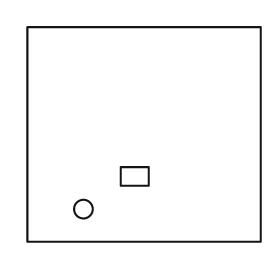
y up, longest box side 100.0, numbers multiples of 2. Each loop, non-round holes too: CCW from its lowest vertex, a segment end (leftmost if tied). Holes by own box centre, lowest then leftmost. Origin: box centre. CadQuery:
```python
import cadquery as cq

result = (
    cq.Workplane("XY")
    .moveTo(-50.0, -46.0)
    .lineTo(50.0, -46.0)
    .lineTo(50.0, 46.0)
    .lineTo(-50.0, 46.0)
    .close()
    .moveTo(-26.0, -32.0)
    .circle(4.0)
    .moveTo(-10.0, -22.0)
    .lineTo(2.0, -22.0)
    .lineTo(2.0, -14.0)
    .lineTo(-10.0, -14.0)
    .close()
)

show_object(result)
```